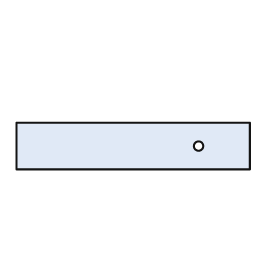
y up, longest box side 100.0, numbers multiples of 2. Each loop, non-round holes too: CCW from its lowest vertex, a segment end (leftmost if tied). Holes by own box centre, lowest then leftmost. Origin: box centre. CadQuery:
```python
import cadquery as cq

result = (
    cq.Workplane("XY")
    .moveTo(-50.0, -10.0)
    .lineTo(50.0, -10.0)
    .lineTo(50.0, 10.0)
    .lineTo(-50.0, 10.0)
    .close()
    .moveTo(28.0, 0.0)
    .circle(2.0)
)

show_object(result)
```